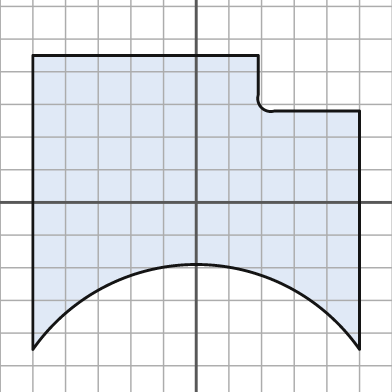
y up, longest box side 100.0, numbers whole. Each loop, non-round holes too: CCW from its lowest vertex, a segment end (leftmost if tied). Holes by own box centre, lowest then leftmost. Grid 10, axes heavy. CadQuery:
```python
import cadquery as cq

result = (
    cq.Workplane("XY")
    .moveTo(-50.0, -45.0)
    .threePointArc((0.0, -19.0), (50.0, -45.0))
    .lineTo(50.0, 28.0)
    .lineTo(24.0, 28.0)
    .threePointArc((20.0, 29.0), (19.0, 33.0))
    .lineTo(19.0, 45.0)
    .lineTo(-50.0, 45.0)
    .close()
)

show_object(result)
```